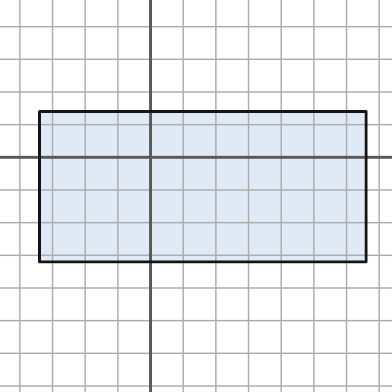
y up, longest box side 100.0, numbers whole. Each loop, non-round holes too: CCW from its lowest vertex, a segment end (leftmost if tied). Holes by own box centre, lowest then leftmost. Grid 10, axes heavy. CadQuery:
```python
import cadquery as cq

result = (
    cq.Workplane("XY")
    .moveTo(-34.0, -32.0)
    .lineTo(66.0, -32.0)
    .lineTo(66.0, 14.0)
    .lineTo(-34.0, 14.0)
    .close()
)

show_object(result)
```